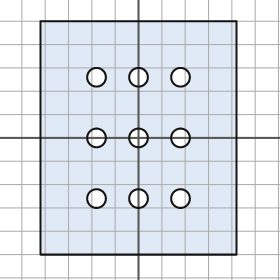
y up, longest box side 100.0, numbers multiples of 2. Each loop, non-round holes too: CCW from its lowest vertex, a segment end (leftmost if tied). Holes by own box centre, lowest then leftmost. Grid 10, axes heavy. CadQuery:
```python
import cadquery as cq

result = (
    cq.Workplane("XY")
    .moveTo(-42.0, -50.0)
    .lineTo(42.0, -50.0)
    .lineTo(42.0, 50.0)
    .lineTo(-42.0, 50.0)
    .close()
    .moveTo(-18.0, -26.0)
    .circle(4.0)
    .moveTo(0.0, -26.0)
    .circle(4.0)
    .moveTo(18.0, -26.0)
    .circle(4.0)
    .moveTo(-18.0, 0.0)
    .circle(4.0)
    .moveTo(0.0, 0.0)
    .circle(4.0)
    .moveTo(18.0, 0.0)
    .circle(4.0)
    .moveTo(-18.0, 26.0)
    .circle(4.0)
    .moveTo(0.0, 26.0)
    .circle(4.0)
    .moveTo(18.0, 26.0)
    .circle(4.0)
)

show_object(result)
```